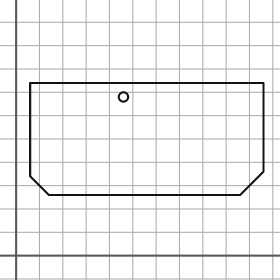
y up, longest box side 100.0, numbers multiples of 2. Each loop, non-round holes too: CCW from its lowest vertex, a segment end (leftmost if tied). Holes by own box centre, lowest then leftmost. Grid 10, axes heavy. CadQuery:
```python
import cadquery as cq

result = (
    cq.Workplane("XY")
    .moveTo(14.0, 26.0)
    .lineTo(96.0, 26.0)
    .lineTo(106.0, 36.0)
    .lineTo(106.0, 74.0)
    .lineTo(6.0, 74.0)
    .lineTo(6.0, 34.0)
    .close()
    .moveTo(46.0, 68.0)
    .circle(2.0)
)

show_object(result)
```